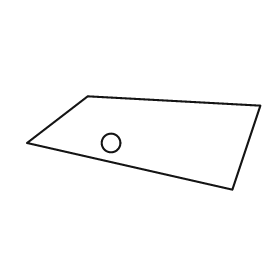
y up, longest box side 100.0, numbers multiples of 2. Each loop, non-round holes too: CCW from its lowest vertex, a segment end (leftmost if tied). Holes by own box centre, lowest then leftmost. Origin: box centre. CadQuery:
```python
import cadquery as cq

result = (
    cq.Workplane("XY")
    .moveTo(38.0, -20.0)
    .lineTo(50.0, 16.0)
    .lineTo(-24.0, 20.0)
    .lineTo(-50.0, 0.0)
    .close()
    .moveTo(-14.0, 0.0)
    .circle(4.0)
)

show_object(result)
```